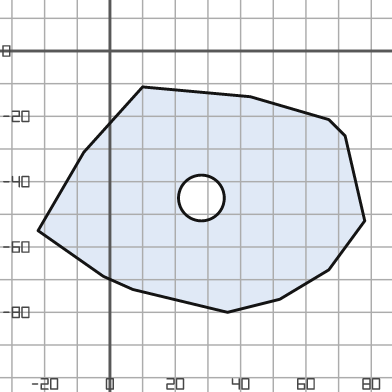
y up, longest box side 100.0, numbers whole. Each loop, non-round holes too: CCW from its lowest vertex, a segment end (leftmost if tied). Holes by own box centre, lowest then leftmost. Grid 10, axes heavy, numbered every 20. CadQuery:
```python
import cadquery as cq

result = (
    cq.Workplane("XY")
    .moveTo(36.0, -80.0)
    .lineTo(52.0, -76.0)
    .lineTo(67.0, -67.0)
    .lineTo(78.0, -52.0)
    .lineTo(72.0, -26.0)
    .lineTo(67.0, -21.0)
    .lineTo(43.0, -14.0)
    .lineTo(10.0, -11.0)
    .lineTo(-8.0, -31.0)
    .lineTo(-22.0, -55.0)
    .lineTo(-2.0, -69.0)
    .lineTo(7.0, -73.0)
    .close()
    .moveTo(28.0, -45.0)
    .circle(7.0)
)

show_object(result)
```